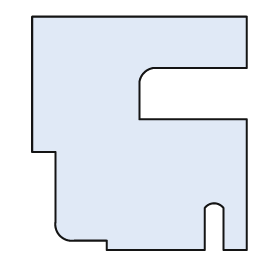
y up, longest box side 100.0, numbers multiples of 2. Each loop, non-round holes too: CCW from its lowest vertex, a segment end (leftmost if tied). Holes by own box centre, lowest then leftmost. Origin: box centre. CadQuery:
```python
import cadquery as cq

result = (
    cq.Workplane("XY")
    .moveTo(-14.0, -50.0)
    .lineTo(28.0, -50.0)
    .lineTo(28.0, -32.0)
    .threePointArc((32.0, -30.0), (36.0, -32.0))
    .lineTo(36.0, -50.0)
    .lineTo(46.0, -50.0)
    .lineTo(46.0, 6.0)
    .lineTo(0.0, 6.0)
    .lineTo(0.0, 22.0)
    .threePointArc((2.0, 26.0), (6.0, 28.0))
    .lineTo(46.0, 28.0)
    .lineTo(46.0, 50.0)
    .lineTo(-46.0, 50.0)
    .lineTo(-46.0, -8.0)
    .lineTo(-36.0, -8.0)
    .lineTo(-36.0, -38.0)
    .threePointArc((-34.0, -44.0), (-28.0, -46.0))
    .lineTo(-14.0, -46.0)
    .close()
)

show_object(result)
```